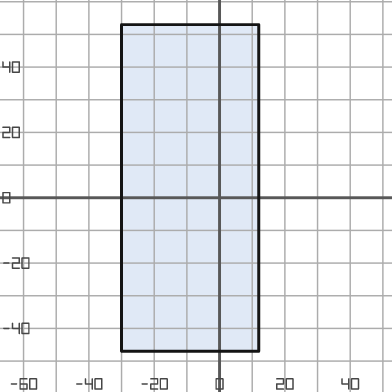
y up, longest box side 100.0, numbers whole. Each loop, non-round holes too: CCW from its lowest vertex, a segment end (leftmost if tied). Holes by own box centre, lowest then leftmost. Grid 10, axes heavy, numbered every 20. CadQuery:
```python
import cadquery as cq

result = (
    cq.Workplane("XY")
    .moveTo(-30.0, -47.0)
    .lineTo(12.0, -47.0)
    .lineTo(12.0, 53.0)
    .lineTo(-30.0, 53.0)
    .close()
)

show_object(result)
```